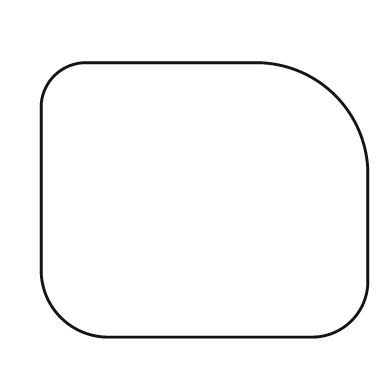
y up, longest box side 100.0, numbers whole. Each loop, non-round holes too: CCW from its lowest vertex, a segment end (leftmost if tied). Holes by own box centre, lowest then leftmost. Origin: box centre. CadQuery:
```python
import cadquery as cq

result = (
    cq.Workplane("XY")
    .moveTo(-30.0, -42.0)
    .lineTo(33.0, -42.0)
    .threePointArc((45.0, -37.0), (50.0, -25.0))
    .lineTo(50.0, 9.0)
    .threePointArc((40.0, 32.0), (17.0, 42.0))
    .lineTo(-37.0, 42.0)
    .threePointArc((-46.0, 38.0), (-50.0, 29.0))
    .lineTo(-50.0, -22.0)
    .threePointArc((-44.0, -36.0), (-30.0, -42.0))
    .close()
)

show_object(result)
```